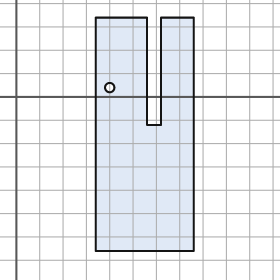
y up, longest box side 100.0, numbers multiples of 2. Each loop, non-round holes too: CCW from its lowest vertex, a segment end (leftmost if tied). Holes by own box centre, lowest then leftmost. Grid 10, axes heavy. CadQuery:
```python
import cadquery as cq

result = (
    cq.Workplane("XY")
    .moveTo(34.0, -66.0)
    .lineTo(76.0, -66.0)
    .lineTo(76.0, 34.0)
    .lineTo(62.0, 34.0)
    .lineTo(62.0, -12.0)
    .lineTo(56.0, -12.0)
    .lineTo(56.0, 34.0)
    .lineTo(34.0, 34.0)
    .close()
    .moveTo(40.0, 4.0)
    .circle(2.0)
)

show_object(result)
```